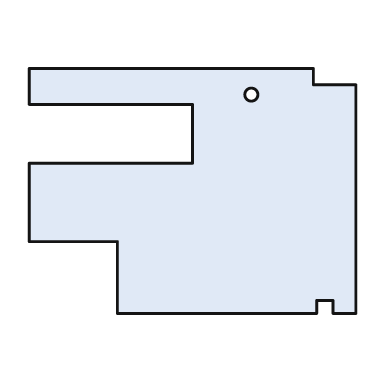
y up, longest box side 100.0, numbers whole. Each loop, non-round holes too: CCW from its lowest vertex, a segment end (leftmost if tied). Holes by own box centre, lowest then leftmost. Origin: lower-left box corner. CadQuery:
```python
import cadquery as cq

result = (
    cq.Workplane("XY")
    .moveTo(27.0, 0.0)
    .lineTo(88.0, 0.0)
    .lineTo(88.0, 4.0)
    .lineTo(93.0, 4.0)
    .lineTo(93.0, 0.0)
    .lineTo(100.0, 0.0)
    .lineTo(100.0, 70.0)
    .lineTo(87.0, 70.0)
    .lineTo(87.0, 75.0)
    .lineTo(0.0, 75.0)
    .lineTo(0.0, 64.0)
    .lineTo(50.0, 64.0)
    .lineTo(50.0, 46.0)
    .lineTo(0.0, 46.0)
    .lineTo(0.0, 22.0)
    .lineTo(27.0, 22.0)
    .close()
    .moveTo(68.0, 67.0)
    .circle(2.0)
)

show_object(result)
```